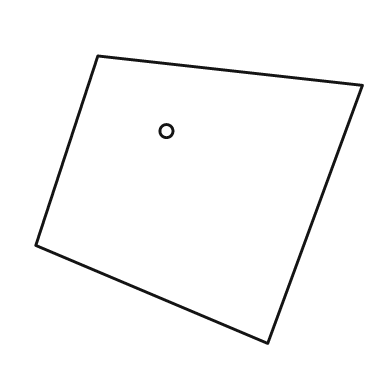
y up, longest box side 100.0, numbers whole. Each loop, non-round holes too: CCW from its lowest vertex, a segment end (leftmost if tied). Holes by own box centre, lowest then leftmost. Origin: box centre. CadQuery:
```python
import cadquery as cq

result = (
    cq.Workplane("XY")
    .moveTo(21.0, -44.0)
    .lineTo(50.0, 35.0)
    .lineTo(-31.0, 44.0)
    .lineTo(-50.0, -14.0)
    .close()
    .moveTo(-10.0, 21.0)
    .circle(2.0)
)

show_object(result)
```